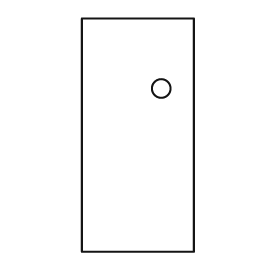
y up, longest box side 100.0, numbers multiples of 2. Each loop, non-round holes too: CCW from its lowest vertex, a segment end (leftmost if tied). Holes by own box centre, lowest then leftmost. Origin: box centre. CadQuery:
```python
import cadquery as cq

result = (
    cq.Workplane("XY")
    .moveTo(-24.0, -50.0)
    .lineTo(24.0, -50.0)
    .lineTo(24.0, 50.0)
    .lineTo(-24.0, 50.0)
    .close()
    .moveTo(10.0, 20.0)
    .circle(4.0)
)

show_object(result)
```